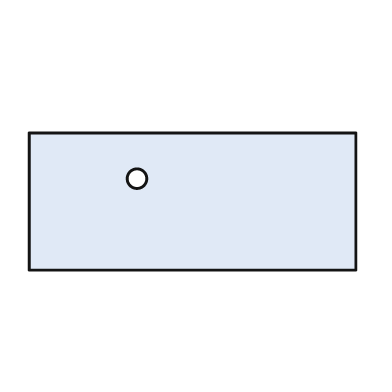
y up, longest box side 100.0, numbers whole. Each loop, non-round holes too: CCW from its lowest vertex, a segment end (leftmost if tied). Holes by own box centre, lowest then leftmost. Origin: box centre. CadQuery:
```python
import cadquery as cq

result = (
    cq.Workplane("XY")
    .moveTo(-50.0, -21.0)
    .lineTo(50.0, -21.0)
    .lineTo(50.0, 21.0)
    .lineTo(-50.0, 21.0)
    .close()
    .moveTo(-17.0, 7.0)
    .circle(3.0)
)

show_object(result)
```